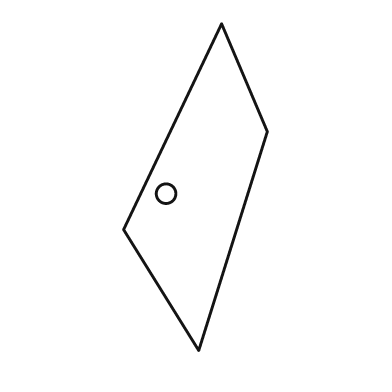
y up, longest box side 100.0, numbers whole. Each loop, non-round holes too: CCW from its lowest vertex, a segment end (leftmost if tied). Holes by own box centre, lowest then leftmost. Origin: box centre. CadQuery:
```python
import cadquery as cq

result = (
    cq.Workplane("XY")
    .moveTo(1.0, -50.0)
    .lineTo(22.0, 17.0)
    .lineTo(8.0, 50.0)
    .lineTo(-22.0, -13.0)
    .close()
    .moveTo(-9.0, -2.0)
    .circle(3.0)
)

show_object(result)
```